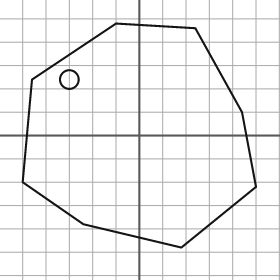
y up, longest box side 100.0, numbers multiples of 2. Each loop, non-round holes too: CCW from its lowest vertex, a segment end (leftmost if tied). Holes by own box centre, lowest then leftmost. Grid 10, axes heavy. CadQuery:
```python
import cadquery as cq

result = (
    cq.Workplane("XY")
    .moveTo(18.0, -48.0)
    .lineTo(50.0, -22.0)
    .lineTo(44.0, 10.0)
    .lineTo(24.0, 46.0)
    .lineTo(-10.0, 48.0)
    .lineTo(-46.0, 24.0)
    .lineTo(-50.0, -20.0)
    .lineTo(-24.0, -38.0)
    .close()
    .moveTo(-30.0, 24.0)
    .circle(4.0)
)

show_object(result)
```